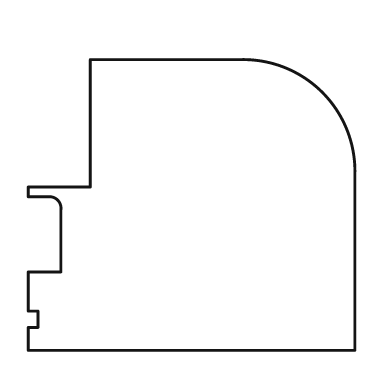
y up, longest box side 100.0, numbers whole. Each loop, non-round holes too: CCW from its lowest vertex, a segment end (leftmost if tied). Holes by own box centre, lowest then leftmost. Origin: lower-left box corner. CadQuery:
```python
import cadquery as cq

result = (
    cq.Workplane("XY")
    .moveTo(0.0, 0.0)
    .lineTo(100.0, 0.0)
    .lineTo(100.0, 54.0)
    .threePointArc((90.0, 79.0), (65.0, 89.0))
    .lineTo(19.0, 89.0)
    .lineTo(19.0, 50.0)
    .lineTo(0.0, 50.0)
    .lineTo(0.0, 47.0)
    .lineTo(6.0, 47.0)
    .threePointArc((9.0, 46.0), (10.0, 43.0))
    .lineTo(10.0, 24.0)
    .lineTo(0.0, 24.0)
    .lineTo(0.0, 12.0)
    .lineTo(3.0, 12.0)
    .lineTo(3.0, 7.0)
    .lineTo(0.0, 7.0)
    .close()
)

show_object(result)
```